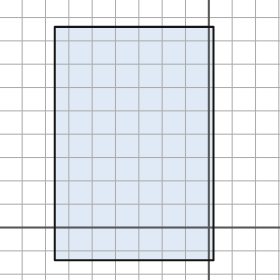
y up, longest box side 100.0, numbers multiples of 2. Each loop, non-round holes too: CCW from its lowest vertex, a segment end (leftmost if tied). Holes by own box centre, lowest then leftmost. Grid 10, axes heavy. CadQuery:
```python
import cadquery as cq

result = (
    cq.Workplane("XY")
    .moveTo(-66.0, -14.0)
    .lineTo(2.0, -14.0)
    .lineTo(2.0, 86.0)
    .lineTo(-66.0, 86.0)
    .close()
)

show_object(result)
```